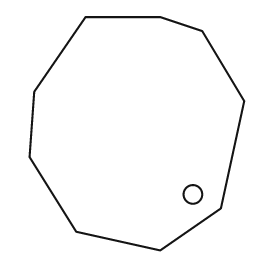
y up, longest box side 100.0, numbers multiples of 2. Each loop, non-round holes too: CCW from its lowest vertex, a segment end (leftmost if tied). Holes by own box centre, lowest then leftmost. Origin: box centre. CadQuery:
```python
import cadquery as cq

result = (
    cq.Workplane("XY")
    .moveTo(10.0, -50.0)
    .lineTo(36.0, -32.0)
    .lineTo(46.0, 14.0)
    .lineTo(28.0, 44.0)
    .lineTo(10.0, 50.0)
    .lineTo(-22.0, 50.0)
    .lineTo(-44.0, 18.0)
    .lineTo(-46.0, -10.0)
    .lineTo(-26.0, -42.0)
    .close()
    .moveTo(24.0, -26.0)
    .circle(4.0)
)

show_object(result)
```